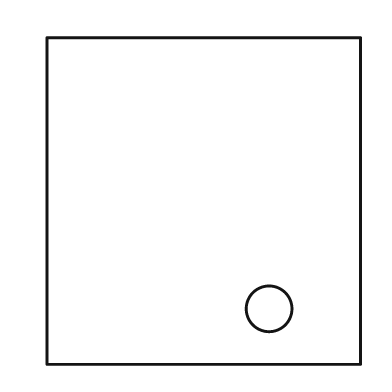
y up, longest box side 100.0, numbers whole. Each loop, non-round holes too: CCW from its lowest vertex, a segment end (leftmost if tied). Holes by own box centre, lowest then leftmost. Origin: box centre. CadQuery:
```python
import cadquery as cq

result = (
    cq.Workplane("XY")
    .moveTo(-48.0, -50.0)
    .lineTo(48.0, -50.0)
    .lineTo(48.0, 50.0)
    .lineTo(-48.0, 50.0)
    .close()
    .moveTo(20.0, -33.0)
    .circle(7.0)
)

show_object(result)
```